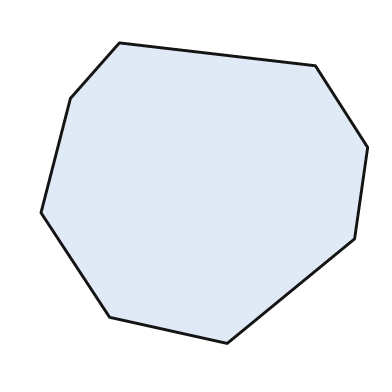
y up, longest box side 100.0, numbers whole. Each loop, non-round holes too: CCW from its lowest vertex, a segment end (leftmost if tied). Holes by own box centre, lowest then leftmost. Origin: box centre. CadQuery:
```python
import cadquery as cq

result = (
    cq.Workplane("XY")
    .moveTo(7.0, -46.0)
    .lineTo(46.0, -14.0)
    .lineTo(50.0, 14.0)
    .lineTo(34.0, 39.0)
    .lineTo(-26.0, 46.0)
    .lineTo(-41.0, 29.0)
    .lineTo(-50.0, -6.0)
    .lineTo(-29.0, -38.0)
    .close()
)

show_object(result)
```